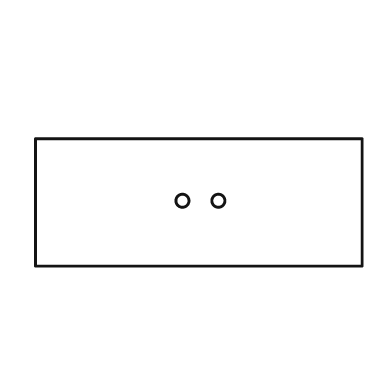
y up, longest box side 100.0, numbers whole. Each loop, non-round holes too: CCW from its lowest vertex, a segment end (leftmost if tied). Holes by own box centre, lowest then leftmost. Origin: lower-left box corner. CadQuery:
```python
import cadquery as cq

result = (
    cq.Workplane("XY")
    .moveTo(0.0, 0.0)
    .lineTo(100.0, 0.0)
    .lineTo(100.0, 39.0)
    .lineTo(0.0, 39.0)
    .close()
    .moveTo(45.0, 20.0)
    .circle(2.0)
    .moveTo(56.0, 20.0)
    .circle(2.0)
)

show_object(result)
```